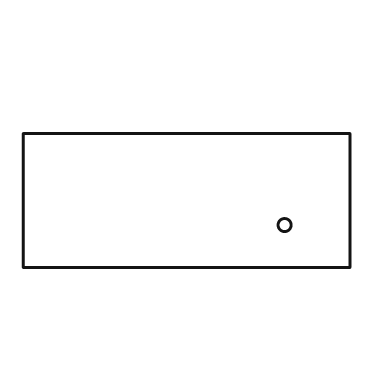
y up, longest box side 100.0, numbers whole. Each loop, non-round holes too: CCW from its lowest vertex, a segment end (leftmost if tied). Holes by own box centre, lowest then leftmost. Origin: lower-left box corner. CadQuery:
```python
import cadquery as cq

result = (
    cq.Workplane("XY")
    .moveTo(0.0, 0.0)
    .lineTo(100.0, 0.0)
    .lineTo(100.0, 41.0)
    .lineTo(0.0, 41.0)
    .close()
    .moveTo(80.0, 13.0)
    .circle(2.0)
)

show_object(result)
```